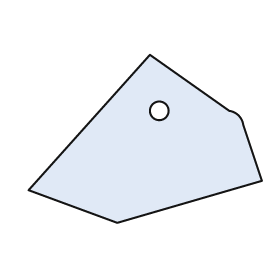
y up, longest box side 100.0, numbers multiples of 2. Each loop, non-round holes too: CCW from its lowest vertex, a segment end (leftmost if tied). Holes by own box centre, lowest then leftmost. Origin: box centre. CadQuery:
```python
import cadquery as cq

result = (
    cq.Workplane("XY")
    .moveTo(-12.0, -36.0)
    .lineTo(50.0, -18.0)
    .lineTo(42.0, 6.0)
    .threePointArc((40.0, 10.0), (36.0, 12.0))
    .lineTo(2.0, 36.0)
    .lineTo(-50.0, -22.0)
    .close()
    .moveTo(6.0, 12.0)
    .circle(4.0)
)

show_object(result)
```